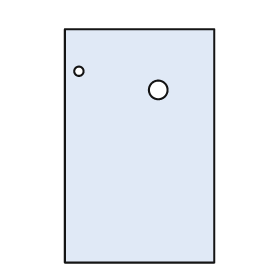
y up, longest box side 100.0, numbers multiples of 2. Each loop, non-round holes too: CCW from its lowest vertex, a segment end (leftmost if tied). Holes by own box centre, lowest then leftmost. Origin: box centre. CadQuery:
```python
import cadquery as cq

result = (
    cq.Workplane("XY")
    .moveTo(-32.0, -50.0)
    .lineTo(32.0, -50.0)
    .lineTo(32.0, 50.0)
    .lineTo(-32.0, 50.0)
    .close()
    .moveTo(8.0, 24.0)
    .circle(4.0)
    .moveTo(-26.0, 32.0)
    .circle(2.0)
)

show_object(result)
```